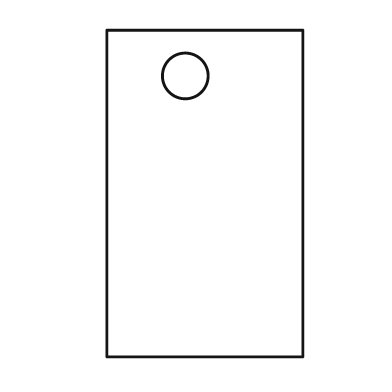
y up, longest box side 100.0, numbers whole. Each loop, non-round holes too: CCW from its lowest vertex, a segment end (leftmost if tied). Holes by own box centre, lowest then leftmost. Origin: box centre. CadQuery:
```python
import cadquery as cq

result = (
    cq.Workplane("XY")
    .moveTo(-30.0, -50.0)
    .lineTo(30.0, -50.0)
    .lineTo(30.0, 50.0)
    .lineTo(-30.0, 50.0)
    .close()
    .moveTo(-6.0, 36.0)
    .circle(7.0)
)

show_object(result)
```